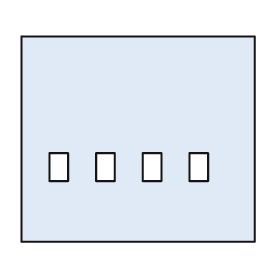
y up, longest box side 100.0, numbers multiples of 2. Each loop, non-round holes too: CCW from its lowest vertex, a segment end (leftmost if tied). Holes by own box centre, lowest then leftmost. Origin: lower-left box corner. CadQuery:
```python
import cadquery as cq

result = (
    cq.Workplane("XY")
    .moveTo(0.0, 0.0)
    .lineTo(100.0, 0.0)
    .lineTo(100.0, 88.0)
    .lineTo(0.0, 88.0)
    .close()
    .moveTo(12.0, 26.0)
    .lineTo(20.0, 26.0)
    .lineTo(20.0, 38.0)
    .lineTo(12.0, 38.0)
    .close()
    .moveTo(32.0, 26.0)
    .lineTo(40.0, 26.0)
    .lineTo(40.0, 38.0)
    .lineTo(32.0, 38.0)
    .close()
    .moveTo(52.0, 26.0)
    .lineTo(60.0, 26.0)
    .lineTo(60.0, 38.0)
    .lineTo(52.0, 38.0)
    .close()
    .moveTo(72.0, 26.0)
    .lineTo(80.0, 26.0)
    .lineTo(80.0, 38.0)
    .lineTo(72.0, 38.0)
    .close()
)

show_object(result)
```